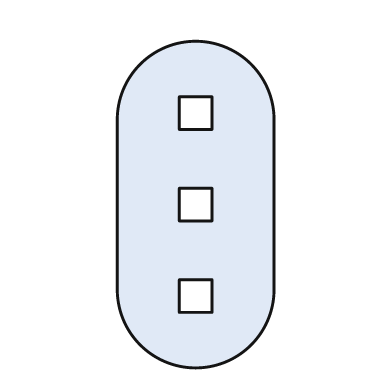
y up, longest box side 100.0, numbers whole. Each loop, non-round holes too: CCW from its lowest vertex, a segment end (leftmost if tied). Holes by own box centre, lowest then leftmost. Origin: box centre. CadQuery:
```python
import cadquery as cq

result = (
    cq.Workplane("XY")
    .moveTo(-24.0, -26.0)
    .threePointArc((0.0, -50.0), (24.0, -26.0))
    .lineTo(24.0, 26.0)
    .threePointArc((0.0, 50.0), (-24.0, 26.0))
    .close()
    .moveTo(-5.0, -33.0)
    .lineTo(5.0, -33.0)
    .lineTo(5.0, -23.0)
    .lineTo(-5.0, -23.0)
    .close()
    .moveTo(-5.0, -5.0)
    .lineTo(5.0, -5.0)
    .lineTo(5.0, 5.0)
    .lineTo(-5.0, 5.0)
    .close()
    .moveTo(-5.0, 23.0)
    .lineTo(5.0, 23.0)
    .lineTo(5.0, 33.0)
    .lineTo(-5.0, 33.0)
    .close()
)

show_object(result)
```